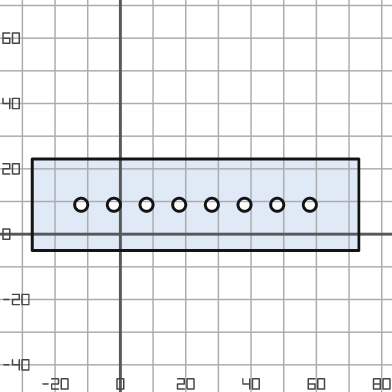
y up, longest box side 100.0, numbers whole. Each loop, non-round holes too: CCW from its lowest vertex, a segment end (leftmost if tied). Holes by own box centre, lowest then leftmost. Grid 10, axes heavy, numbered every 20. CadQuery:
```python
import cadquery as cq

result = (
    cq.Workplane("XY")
    .moveTo(-27.0, -5.0)
    .lineTo(73.0, -5.0)
    .lineTo(73.0, 23.0)
    .lineTo(-27.0, 23.0)
    .close()
    .moveTo(-12.0, 9.0)
    .circle(2.0)
    .moveTo(-2.0, 9.0)
    .circle(2.0)
    .moveTo(8.0, 9.0)
    .circle(2.0)
    .moveTo(18.0, 9.0)
    .circle(2.0)
    .moveTo(28.0, 9.0)
    .circle(2.0)
    .moveTo(38.0, 9.0)
    .circle(2.0)
    .moveTo(48.0, 9.0)
    .circle(2.0)
    .moveTo(58.0, 9.0)
    .circle(2.0)
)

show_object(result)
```